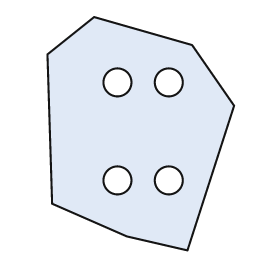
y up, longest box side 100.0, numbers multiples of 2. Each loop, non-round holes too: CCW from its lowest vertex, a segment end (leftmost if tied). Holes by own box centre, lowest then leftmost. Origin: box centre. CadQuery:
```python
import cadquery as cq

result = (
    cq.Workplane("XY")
    .moveTo(20.0, -50.0)
    .lineTo(40.0, 12.0)
    .lineTo(22.0, 38.0)
    .lineTo(-20.0, 50.0)
    .lineTo(-40.0, 34.0)
    .lineTo(-38.0, -30.0)
    .lineTo(-6.0, -44.0)
    .close()
    .moveTo(-10.0, -20.0)
    .circle(6.0)
    .moveTo(12.0, -20.0)
    .circle(6.0)
    .moveTo(-10.0, 22.0)
    .circle(6.0)
    .moveTo(12.0, 22.0)
    .circle(6.0)
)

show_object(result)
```